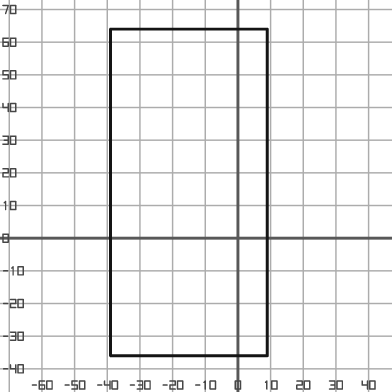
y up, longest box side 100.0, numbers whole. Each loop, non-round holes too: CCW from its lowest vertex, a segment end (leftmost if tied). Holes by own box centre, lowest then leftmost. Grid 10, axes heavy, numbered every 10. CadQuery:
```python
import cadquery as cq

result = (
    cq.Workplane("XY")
    .moveTo(-39.0, -36.0)
    .lineTo(9.0, -36.0)
    .lineTo(9.0, 64.0)
    .lineTo(-39.0, 64.0)
    .close()
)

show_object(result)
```